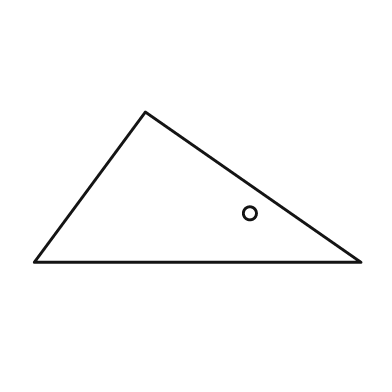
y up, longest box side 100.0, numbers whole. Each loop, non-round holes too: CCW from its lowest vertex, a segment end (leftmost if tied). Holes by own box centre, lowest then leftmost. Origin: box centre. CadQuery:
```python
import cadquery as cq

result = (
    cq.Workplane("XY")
    .moveTo(-50.0, -23.0)
    .lineTo(50.0, -23.0)
    .lineTo(-16.0, 23.0)
    .close()
    .moveTo(16.0, -8.0)
    .circle(2.0)
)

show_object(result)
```